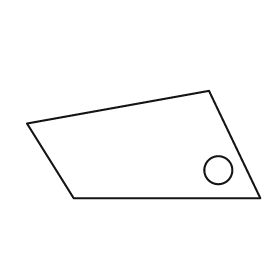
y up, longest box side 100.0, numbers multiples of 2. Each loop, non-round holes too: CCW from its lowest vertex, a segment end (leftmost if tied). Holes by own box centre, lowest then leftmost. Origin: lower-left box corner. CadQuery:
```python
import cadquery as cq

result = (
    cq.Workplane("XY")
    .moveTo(20.0, 0.0)
    .lineTo(100.0, 0.0)
    .lineTo(78.0, 46.0)
    .lineTo(0.0, 32.0)
    .close()
    .moveTo(82.0, 12.0)
    .circle(6.0)
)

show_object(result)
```